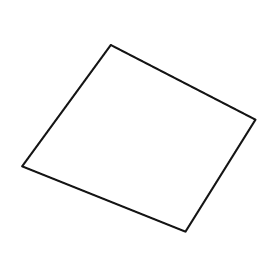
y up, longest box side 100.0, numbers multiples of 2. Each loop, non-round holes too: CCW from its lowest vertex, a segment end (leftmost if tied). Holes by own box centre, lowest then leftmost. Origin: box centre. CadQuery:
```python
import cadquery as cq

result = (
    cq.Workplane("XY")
    .moveTo(20.0, -40.0)
    .lineTo(50.0, 8.0)
    .lineTo(-12.0, 40.0)
    .lineTo(-50.0, -12.0)
    .close()
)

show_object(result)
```